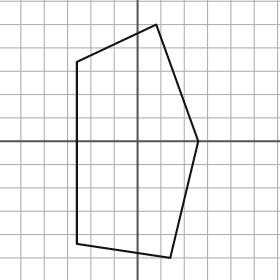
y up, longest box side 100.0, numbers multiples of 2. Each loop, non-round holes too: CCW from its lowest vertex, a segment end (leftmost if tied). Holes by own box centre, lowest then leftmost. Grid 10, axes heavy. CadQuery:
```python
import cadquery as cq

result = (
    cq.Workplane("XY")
    .moveTo(14.0, -50.0)
    .lineTo(26.0, 0.0)
    .lineTo(8.0, 50.0)
    .lineTo(-26.0, 34.0)
    .lineTo(-26.0, -44.0)
    .close()
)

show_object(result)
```